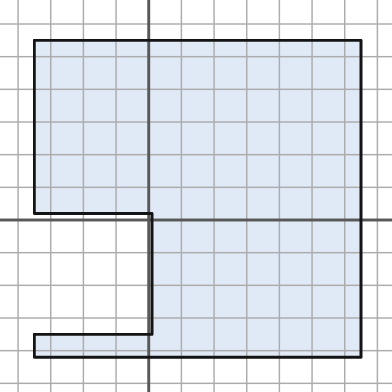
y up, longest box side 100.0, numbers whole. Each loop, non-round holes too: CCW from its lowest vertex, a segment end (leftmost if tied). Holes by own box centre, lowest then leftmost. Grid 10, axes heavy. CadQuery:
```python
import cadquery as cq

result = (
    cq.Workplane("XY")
    .moveTo(-35.0, -42.0)
    .lineTo(65.0, -42.0)
    .lineTo(65.0, 55.0)
    .lineTo(-35.0, 55.0)
    .lineTo(-35.0, 2.0)
    .lineTo(1.0, 2.0)
    .lineTo(1.0, -35.0)
    .lineTo(-35.0, -35.0)
    .close()
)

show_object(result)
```